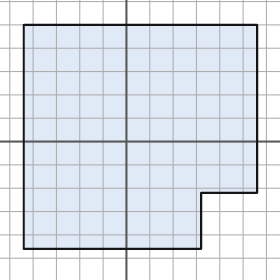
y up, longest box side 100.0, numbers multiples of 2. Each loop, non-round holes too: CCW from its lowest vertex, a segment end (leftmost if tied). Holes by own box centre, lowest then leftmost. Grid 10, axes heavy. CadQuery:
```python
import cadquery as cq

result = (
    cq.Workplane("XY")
    .moveTo(-44.0, -46.0)
    .lineTo(32.0, -46.0)
    .lineTo(32.0, -22.0)
    .lineTo(56.0, -22.0)
    .lineTo(56.0, 50.0)
    .lineTo(-44.0, 50.0)
    .close()
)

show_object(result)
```